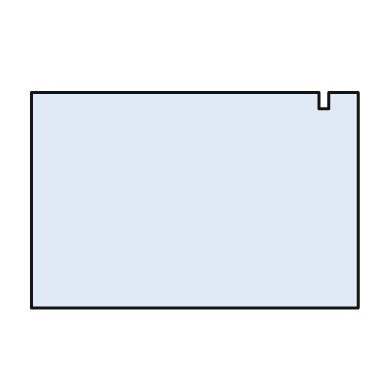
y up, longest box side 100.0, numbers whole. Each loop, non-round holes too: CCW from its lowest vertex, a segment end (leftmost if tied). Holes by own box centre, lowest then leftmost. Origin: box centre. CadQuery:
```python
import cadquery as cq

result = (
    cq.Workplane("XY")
    .moveTo(-50.0, -33.0)
    .lineTo(50.0, -33.0)
    .lineTo(50.0, 33.0)
    .lineTo(41.0, 33.0)
    .lineTo(41.0, 28.0)
    .lineTo(38.0, 28.0)
    .lineTo(38.0, 33.0)
    .lineTo(-50.0, 33.0)
    .close()
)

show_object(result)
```